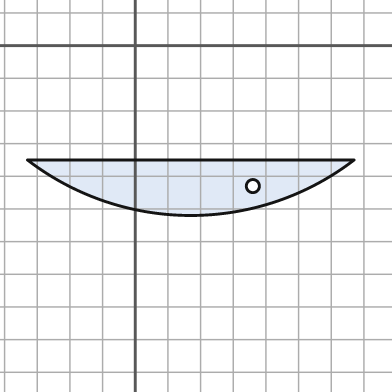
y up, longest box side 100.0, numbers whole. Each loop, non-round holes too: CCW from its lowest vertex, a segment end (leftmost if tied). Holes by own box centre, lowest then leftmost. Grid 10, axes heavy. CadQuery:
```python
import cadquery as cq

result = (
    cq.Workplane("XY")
    .moveTo(-33.0, -35.0)
    .threePointArc((17.0, -52.0), (67.0, -35.0))
    .close()
    .moveTo(36.0, -43.0)
    .circle(2.0)
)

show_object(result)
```